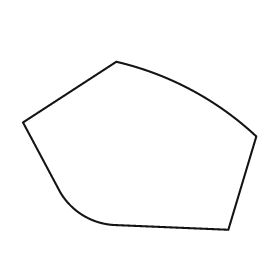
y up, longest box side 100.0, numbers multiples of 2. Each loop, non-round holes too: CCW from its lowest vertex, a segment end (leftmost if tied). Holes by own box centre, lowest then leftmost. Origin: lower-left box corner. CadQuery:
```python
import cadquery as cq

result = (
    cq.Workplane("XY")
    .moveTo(88.0, 0.0)
    .lineTo(100.0, 40.0)
    .threePointArc((72.0, 60.0), (40.0, 72.0))
    .lineTo(0.0, 46.0)
    .lineTo(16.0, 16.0)
    .threePointArc((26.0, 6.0), (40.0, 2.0))
    .close()
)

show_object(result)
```